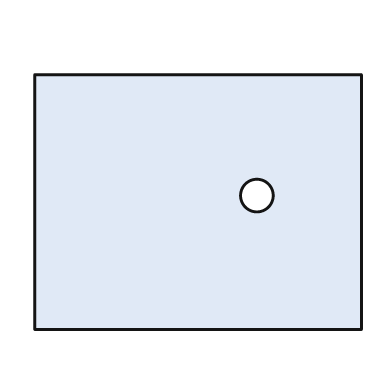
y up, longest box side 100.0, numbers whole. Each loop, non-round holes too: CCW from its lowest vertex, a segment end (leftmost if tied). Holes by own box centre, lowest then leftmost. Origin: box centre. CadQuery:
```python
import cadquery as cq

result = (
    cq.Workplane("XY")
    .moveTo(-50.0, -39.0)
    .lineTo(50.0, -39.0)
    .lineTo(50.0, 39.0)
    .lineTo(-50.0, 39.0)
    .close()
    .moveTo(18.0, 2.0)
    .circle(5.0)
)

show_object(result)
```